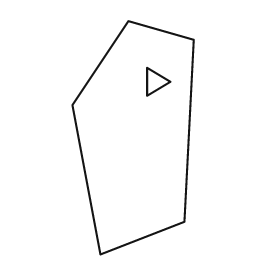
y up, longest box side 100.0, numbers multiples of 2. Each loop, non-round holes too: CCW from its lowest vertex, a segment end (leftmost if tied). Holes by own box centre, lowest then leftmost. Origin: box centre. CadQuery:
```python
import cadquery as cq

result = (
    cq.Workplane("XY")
    .moveTo(-14.0, -50.0)
    .lineTo(22.0, -36.0)
    .lineTo(26.0, 42.0)
    .lineTo(-2.0, 50.0)
    .lineTo(-26.0, 14.0)
    .close()
    .moveTo(6.0, 18.0)
    .lineTo(16.0, 24.0)
    .lineTo(6.0, 30.0)
    .close()
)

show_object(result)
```